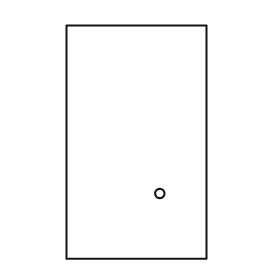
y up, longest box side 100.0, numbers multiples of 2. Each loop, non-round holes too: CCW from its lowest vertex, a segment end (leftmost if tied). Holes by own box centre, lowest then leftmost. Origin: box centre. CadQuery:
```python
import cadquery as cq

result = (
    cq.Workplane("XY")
    .moveTo(-30.0, -50.0)
    .lineTo(30.0, -50.0)
    .lineTo(30.0, 50.0)
    .lineTo(-30.0, 50.0)
    .close()
    .moveTo(10.0, -22.0)
    .circle(2.0)
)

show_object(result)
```